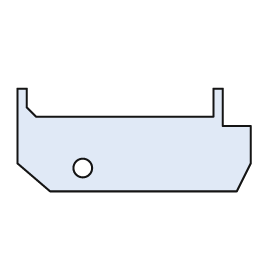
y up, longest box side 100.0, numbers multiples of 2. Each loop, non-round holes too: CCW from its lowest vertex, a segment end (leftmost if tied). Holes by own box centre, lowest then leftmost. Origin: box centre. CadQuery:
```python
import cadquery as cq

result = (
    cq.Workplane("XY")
    .moveTo(-36.0, -22.0)
    .lineTo(44.0, -22.0)
    .lineTo(50.0, -10.0)
    .lineTo(50.0, 6.0)
    .lineTo(38.0, 6.0)
    .lineTo(38.0, 22.0)
    .lineTo(34.0, 22.0)
    .lineTo(34.0, 10.0)
    .lineTo(-42.0, 10.0)
    .lineTo(-46.0, 14.0)
    .lineTo(-46.0, 22.0)
    .lineTo(-50.0, 22.0)
    .lineTo(-50.0, -10.0)
    .close()
    .moveTo(-22.0, -12.0)
    .circle(4.0)
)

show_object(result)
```